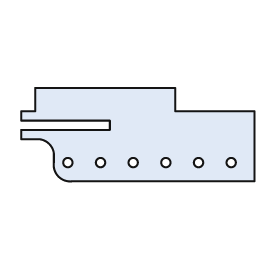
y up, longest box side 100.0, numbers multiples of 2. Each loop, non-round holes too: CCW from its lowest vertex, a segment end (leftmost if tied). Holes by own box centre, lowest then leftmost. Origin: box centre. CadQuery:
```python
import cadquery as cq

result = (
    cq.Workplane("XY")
    .moveTo(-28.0, -20.0)
    .lineTo(50.0, -20.0)
    .lineTo(50.0, 10.0)
    .lineTo(16.0, 10.0)
    .lineTo(16.0, 20.0)
    .lineTo(-44.0, 20.0)
    .lineTo(-44.0, 10.0)
    .lineTo(-50.0, 10.0)
    .lineTo(-50.0, 6.0)
    .lineTo(-12.0, 6.0)
    .lineTo(-12.0, 2.0)
    .lineTo(-50.0, 2.0)
    .lineTo(-50.0, -2.0)
    .lineTo(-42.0, -2.0)
    .threePointArc((-38.0, -4.0), (-36.0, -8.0))
    .lineTo(-36.0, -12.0)
    .threePointArc((-34.0, -18.0), (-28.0, -20.0))
    .close()
    .moveTo(-30.0, -12.0)
    .circle(2.0)
    .moveTo(-16.0, -12.0)
    .circle(2.0)
    .moveTo(-2.0, -12.0)
    .circle(2.0)
    .moveTo(12.0, -12.0)
    .circle(2.0)
    .moveTo(26.0, -12.0)
    .circle(2.0)
    .moveTo(40.0, -12.0)
    .circle(2.0)
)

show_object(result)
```